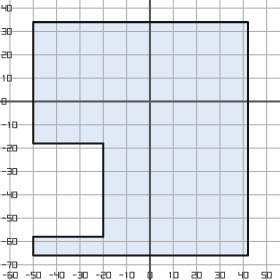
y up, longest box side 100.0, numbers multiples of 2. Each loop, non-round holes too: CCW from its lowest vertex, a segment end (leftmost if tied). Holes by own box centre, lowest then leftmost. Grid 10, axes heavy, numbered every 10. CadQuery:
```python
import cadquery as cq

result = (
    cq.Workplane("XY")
    .moveTo(-50.0, -66.0)
    .lineTo(42.0, -66.0)
    .lineTo(42.0, 34.0)
    .lineTo(-50.0, 34.0)
    .lineTo(-50.0, -18.0)
    .lineTo(-20.0, -18.0)
    .lineTo(-20.0, -58.0)
    .lineTo(-50.0, -58.0)
    .close()
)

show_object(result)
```